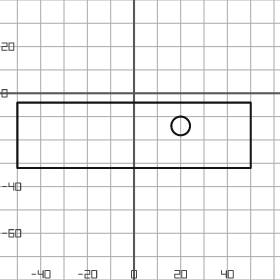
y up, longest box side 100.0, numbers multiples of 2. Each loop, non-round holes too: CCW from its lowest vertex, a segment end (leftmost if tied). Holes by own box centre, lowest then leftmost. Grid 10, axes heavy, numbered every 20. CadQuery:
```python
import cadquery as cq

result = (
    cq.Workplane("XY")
    .moveTo(-50.0, -32.0)
    .lineTo(50.0, -32.0)
    .lineTo(50.0, -4.0)
    .lineTo(-50.0, -4.0)
    .close()
    .moveTo(20.0, -14.0)
    .circle(4.0)
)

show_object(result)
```